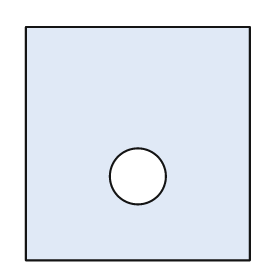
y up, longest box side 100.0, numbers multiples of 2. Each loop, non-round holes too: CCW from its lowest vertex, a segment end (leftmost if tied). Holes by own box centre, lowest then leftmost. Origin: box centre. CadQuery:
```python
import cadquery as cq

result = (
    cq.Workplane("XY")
    .moveTo(-48.0, -50.0)
    .lineTo(48.0, -50.0)
    .lineTo(48.0, 50.0)
    .lineTo(-48.0, 50.0)
    .close()
    .moveTo(0.0, -14.0)
    .circle(12.0)
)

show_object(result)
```